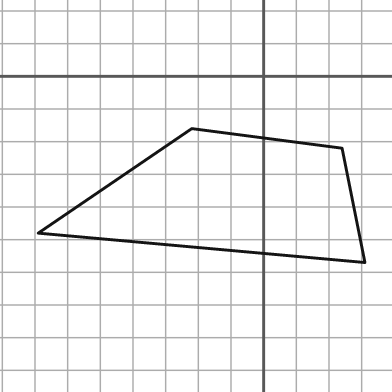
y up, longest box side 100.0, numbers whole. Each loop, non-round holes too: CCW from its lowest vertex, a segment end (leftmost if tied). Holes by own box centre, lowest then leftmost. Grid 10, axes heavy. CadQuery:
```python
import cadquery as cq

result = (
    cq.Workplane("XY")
    .moveTo(31.0, -57.0)
    .lineTo(24.0, -22.0)
    .lineTo(-22.0, -16.0)
    .lineTo(-69.0, -48.0)
    .close()
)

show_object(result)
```